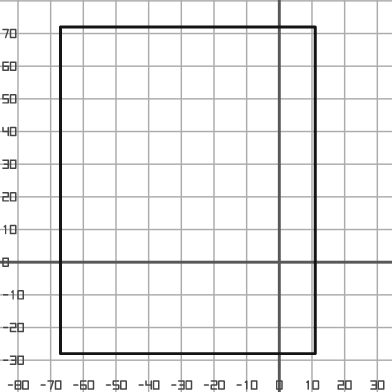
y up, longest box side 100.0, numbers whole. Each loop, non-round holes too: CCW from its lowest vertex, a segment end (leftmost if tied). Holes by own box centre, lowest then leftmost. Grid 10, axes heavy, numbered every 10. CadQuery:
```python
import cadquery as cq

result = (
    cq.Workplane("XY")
    .moveTo(-67.0, -28.0)
    .lineTo(11.0, -28.0)
    .lineTo(11.0, 72.0)
    .lineTo(-67.0, 72.0)
    .close()
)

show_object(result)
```